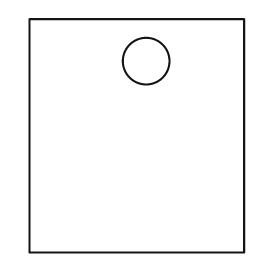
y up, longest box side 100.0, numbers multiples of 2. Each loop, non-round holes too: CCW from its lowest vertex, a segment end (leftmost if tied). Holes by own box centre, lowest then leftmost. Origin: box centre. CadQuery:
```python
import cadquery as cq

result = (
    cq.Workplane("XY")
    .moveTo(-46.0, -50.0)
    .lineTo(46.0, -50.0)
    .lineTo(46.0, 50.0)
    .lineTo(-46.0, 50.0)
    .close()
    .moveTo(4.0, 32.0)
    .circle(10.0)
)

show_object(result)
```